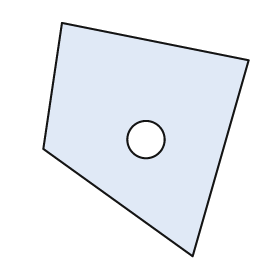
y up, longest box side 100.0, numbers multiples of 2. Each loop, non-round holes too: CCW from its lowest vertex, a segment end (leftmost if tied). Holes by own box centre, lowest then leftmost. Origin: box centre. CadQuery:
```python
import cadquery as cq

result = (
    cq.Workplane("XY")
    .moveTo(20.0, -50.0)
    .lineTo(44.0, 34.0)
    .lineTo(-36.0, 50.0)
    .lineTo(-44.0, -4.0)
    .close()
    .moveTo(0.0, 0.0)
    .circle(8.0)
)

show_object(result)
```